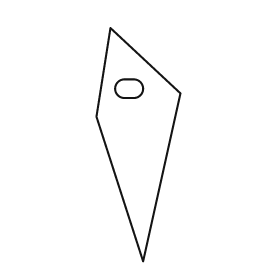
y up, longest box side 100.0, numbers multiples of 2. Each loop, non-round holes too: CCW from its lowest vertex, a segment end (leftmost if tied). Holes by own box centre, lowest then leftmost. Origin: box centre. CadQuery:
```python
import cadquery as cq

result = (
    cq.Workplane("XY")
    .moveTo(2.0, -50.0)
    .lineTo(18.0, 22.0)
    .lineTo(-12.0, 50.0)
    .lineTo(-18.0, 12.0)
    .close()
    .moveTo(-6.0, 20.0)
    .lineTo(-2.0, 20.0)
    .threePointArc((2.0, 24.0), (-2.0, 28.0))
    .lineTo(-6.0, 28.0)
    .threePointArc((-10.0, 24.0), (-6.0, 20.0))
    .close()
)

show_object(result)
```